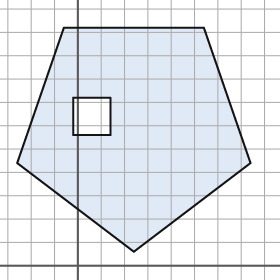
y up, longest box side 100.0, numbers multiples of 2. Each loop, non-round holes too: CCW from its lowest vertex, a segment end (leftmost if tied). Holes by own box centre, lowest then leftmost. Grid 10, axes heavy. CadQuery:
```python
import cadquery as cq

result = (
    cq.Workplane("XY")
    .moveTo(24.0, 6.0)
    .lineTo(74.0, 44.0)
    .lineTo(54.0, 102.0)
    .lineTo(-6.0, 102.0)
    .lineTo(-26.0, 44.0)
    .close()
    .moveTo(-2.0, 56.0)
    .lineTo(14.0, 56.0)
    .lineTo(14.0, 72.0)
    .lineTo(-2.0, 72.0)
    .close()
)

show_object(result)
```